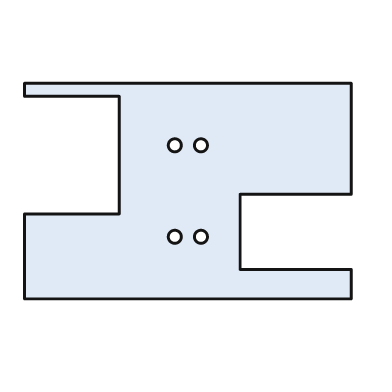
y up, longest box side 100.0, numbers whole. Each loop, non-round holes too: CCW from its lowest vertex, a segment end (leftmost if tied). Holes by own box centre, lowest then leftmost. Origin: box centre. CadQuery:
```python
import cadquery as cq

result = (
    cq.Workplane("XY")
    .moveTo(-50.0, -33.0)
    .lineTo(50.0, -33.0)
    .lineTo(50.0, -24.0)
    .lineTo(16.0, -24.0)
    .lineTo(16.0, -1.0)
    .lineTo(50.0, -1.0)
    .lineTo(50.0, 33.0)
    .lineTo(-50.0, 33.0)
    .lineTo(-50.0, 29.0)
    .lineTo(-21.0, 29.0)
    .lineTo(-21.0, -7.0)
    .lineTo(-50.0, -7.0)
    .close()
    .moveTo(-4.0, -14.0)
    .circle(2.0)
    .moveTo(4.0, -14.0)
    .circle(2.0)
    .moveTo(-4.0, 14.0)
    .circle(2.0)
    .moveTo(4.0, 14.0)
    .circle(2.0)
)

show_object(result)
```